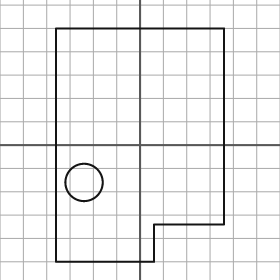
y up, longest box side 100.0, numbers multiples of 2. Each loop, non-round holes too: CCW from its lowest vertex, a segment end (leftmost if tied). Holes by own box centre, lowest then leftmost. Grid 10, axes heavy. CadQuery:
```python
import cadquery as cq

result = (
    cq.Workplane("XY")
    .moveTo(-36.0, -50.0)
    .lineTo(6.0, -50.0)
    .lineTo(6.0, -34.0)
    .lineTo(36.0, -34.0)
    .lineTo(36.0, 50.0)
    .lineTo(-36.0, 50.0)
    .close()
    .moveTo(-24.0, -16.0)
    .circle(8.0)
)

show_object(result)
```